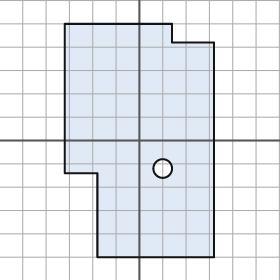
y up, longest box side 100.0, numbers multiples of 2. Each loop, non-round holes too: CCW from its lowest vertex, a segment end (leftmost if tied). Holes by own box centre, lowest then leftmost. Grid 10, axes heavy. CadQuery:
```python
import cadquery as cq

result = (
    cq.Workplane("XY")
    .moveTo(-18.0, -50.0)
    .lineTo(32.0, -50.0)
    .lineTo(32.0, 42.0)
    .lineTo(14.0, 42.0)
    .lineTo(14.0, 50.0)
    .lineTo(-32.0, 50.0)
    .lineTo(-32.0, -14.0)
    .lineTo(-18.0, -14.0)
    .close()
    .moveTo(10.0, -12.0)
    .circle(4.0)
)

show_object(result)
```